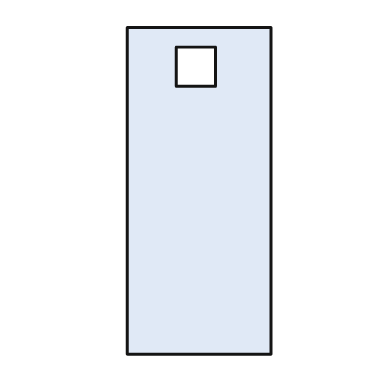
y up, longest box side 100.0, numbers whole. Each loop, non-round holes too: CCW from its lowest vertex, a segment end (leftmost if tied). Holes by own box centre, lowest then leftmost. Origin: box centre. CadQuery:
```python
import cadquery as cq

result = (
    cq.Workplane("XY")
    .moveTo(-22.0, -50.0)
    .lineTo(22.0, -50.0)
    .lineTo(22.0, 50.0)
    .lineTo(-22.0, 50.0)
    .close()
    .moveTo(-7.0, 32.0)
    .lineTo(5.0, 32.0)
    .lineTo(5.0, 44.0)
    .lineTo(-7.0, 44.0)
    .close()
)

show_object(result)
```